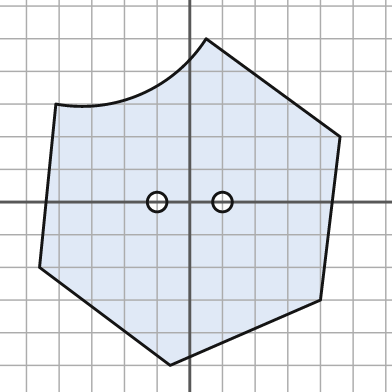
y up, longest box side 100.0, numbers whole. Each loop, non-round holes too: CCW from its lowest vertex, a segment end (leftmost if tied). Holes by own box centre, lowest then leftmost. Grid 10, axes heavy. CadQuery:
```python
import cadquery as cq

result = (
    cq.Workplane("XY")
    .moveTo(-6.0, -50.0)
    .lineTo(40.0, -30.0)
    .lineTo(46.0, 20.0)
    .lineTo(5.0, 50.0)
    .threePointArc((-15.0, 33.0), (-41.0, 30.0))
    .lineTo(-46.0, -20.0)
    .close()
    .moveTo(-10.0, 0.0)
    .circle(3.0)
    .moveTo(10.0, 0.0)
    .circle(3.0)
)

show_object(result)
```